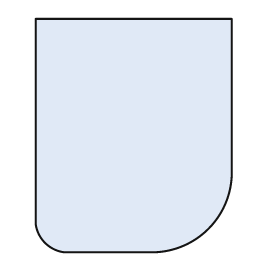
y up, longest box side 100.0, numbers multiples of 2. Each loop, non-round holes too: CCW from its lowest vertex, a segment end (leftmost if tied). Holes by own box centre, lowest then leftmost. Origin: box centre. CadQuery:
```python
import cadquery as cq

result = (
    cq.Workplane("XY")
    .moveTo(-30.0, -50.0)
    .lineTo(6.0, -50.0)
    .threePointArc((32.0, -40.0), (42.0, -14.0))
    .lineTo(42.0, 50.0)
    .lineTo(-42.0, 50.0)
    .lineTo(-42.0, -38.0)
    .threePointArc((-38.0, -46.0), (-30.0, -50.0))
    .close()
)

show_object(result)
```